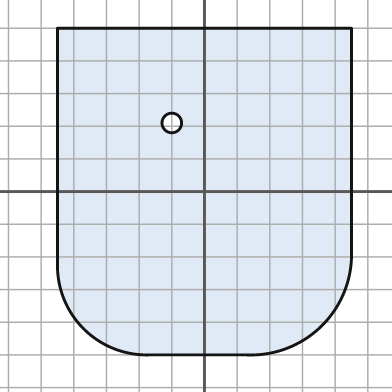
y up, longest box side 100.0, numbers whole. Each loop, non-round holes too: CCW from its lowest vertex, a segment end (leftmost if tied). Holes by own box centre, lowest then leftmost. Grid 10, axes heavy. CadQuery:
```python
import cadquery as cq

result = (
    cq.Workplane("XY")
    .moveTo(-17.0, -50.0)
    .lineTo(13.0, -50.0)
    .threePointArc((36.0, -41.0), (45.0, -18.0))
    .lineTo(45.0, 50.0)
    .lineTo(-45.0, 50.0)
    .lineTo(-45.0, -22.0)
    .threePointArc((-37.0, -42.0), (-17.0, -50.0))
    .close()
    .moveTo(-10.0, 21.0)
    .circle(3.0)
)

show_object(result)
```